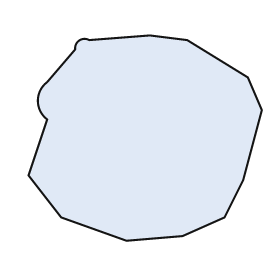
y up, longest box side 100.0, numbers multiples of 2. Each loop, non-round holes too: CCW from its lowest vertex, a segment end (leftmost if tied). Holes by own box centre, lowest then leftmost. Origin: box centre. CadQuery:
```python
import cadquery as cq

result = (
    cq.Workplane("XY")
    .moveTo(-8.0, -44.0)
    .lineTo(16.0, -42.0)
    .lineTo(34.0, -34.0)
    .lineTo(42.0, -18.0)
    .lineTo(50.0, 12.0)
    .lineTo(44.0, 26.0)
    .lineTo(18.0, 42.0)
    .lineTo(2.0, 44.0)
    .lineTo(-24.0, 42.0)
    .threePointArc((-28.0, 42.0), (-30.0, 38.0))
    .lineTo(-42.0, 24.0)
    .threePointArc((-46.0, 16.0), (-42.0, 8.0))
    .lineTo(-50.0, -16.0)
    .lineTo(-36.0, -34.0)
    .close()
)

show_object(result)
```